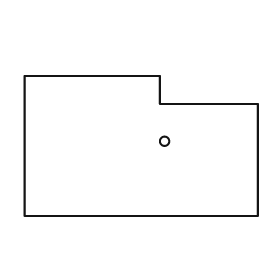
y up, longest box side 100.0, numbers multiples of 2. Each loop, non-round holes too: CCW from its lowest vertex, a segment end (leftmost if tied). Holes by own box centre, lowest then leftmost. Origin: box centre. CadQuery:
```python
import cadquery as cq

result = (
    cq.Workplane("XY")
    .moveTo(-50.0, -30.0)
    .lineTo(50.0, -30.0)
    .lineTo(50.0, 18.0)
    .lineTo(8.0, 18.0)
    .lineTo(8.0, 30.0)
    .lineTo(-50.0, 30.0)
    .close()
    .moveTo(10.0, 2.0)
    .circle(2.0)
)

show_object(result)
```